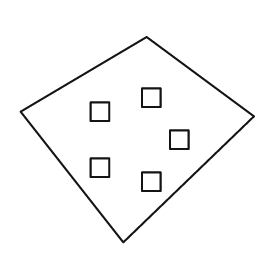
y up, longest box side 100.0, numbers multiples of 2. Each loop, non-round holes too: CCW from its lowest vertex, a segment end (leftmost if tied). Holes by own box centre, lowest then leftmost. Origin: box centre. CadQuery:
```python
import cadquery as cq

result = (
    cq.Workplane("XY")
    .moveTo(-6.0, -44.0)
    .lineTo(50.0, 10.0)
    .lineTo(4.0, 44.0)
    .lineTo(-50.0, 12.0)
    .close()
    .moveTo(2.0, -22.0)
    .lineTo(10.0, -22.0)
    .lineTo(10.0, -14.0)
    .lineTo(2.0, -14.0)
    .close()
    .moveTo(-20.0, -16.0)
    .lineTo(-12.0, -16.0)
    .lineTo(-12.0, -8.0)
    .lineTo(-20.0, -8.0)
    .close()
    .moveTo(14.0, -4.0)
    .lineTo(22.0, -4.0)
    .lineTo(22.0, 4.0)
    .lineTo(14.0, 4.0)
    .close()
    .moveTo(-20.0, 8.0)
    .lineTo(-12.0, 8.0)
    .lineTo(-12.0, 16.0)
    .lineTo(-20.0, 16.0)
    .close()
    .moveTo(2.0, 14.0)
    .lineTo(10.0, 14.0)
    .lineTo(10.0, 22.0)
    .lineTo(2.0, 22.0)
    .close()
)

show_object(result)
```